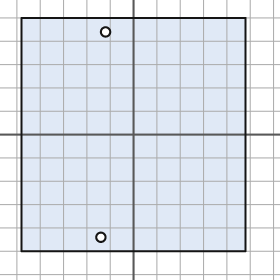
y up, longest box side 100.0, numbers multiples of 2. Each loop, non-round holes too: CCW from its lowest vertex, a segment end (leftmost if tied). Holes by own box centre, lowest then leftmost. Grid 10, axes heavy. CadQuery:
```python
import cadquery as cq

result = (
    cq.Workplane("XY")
    .moveTo(-48.0, -50.0)
    .lineTo(48.0, -50.0)
    .lineTo(48.0, 50.0)
    .lineTo(-48.0, 50.0)
    .close()
    .moveTo(-14.0, -44.0)
    .circle(2.0)
    .moveTo(-12.0, 44.0)
    .circle(2.0)
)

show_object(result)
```